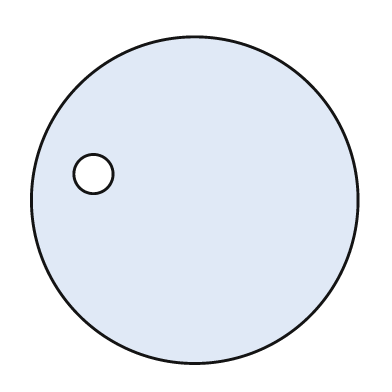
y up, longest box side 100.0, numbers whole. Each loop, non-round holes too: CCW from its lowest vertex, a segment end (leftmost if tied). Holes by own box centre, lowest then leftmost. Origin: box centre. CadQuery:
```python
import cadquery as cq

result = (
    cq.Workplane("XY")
    .moveTo(0.0, 0.0)
    .circle(50.0)
    .moveTo(-31.0, 8.0)
    .circle(6.0)
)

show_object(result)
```